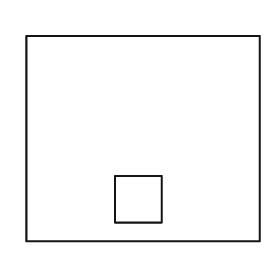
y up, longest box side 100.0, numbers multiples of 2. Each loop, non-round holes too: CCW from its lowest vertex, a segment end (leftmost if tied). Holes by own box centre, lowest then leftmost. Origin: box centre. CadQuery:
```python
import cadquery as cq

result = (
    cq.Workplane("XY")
    .moveTo(-50.0, -44.0)
    .lineTo(50.0, -44.0)
    .lineTo(50.0, 44.0)
    .lineTo(-50.0, 44.0)
    .close()
    .moveTo(-12.0, -36.0)
    .lineTo(8.0, -36.0)
    .lineTo(8.0, -16.0)
    .lineTo(-12.0, -16.0)
    .close()
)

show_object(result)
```